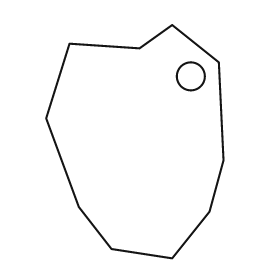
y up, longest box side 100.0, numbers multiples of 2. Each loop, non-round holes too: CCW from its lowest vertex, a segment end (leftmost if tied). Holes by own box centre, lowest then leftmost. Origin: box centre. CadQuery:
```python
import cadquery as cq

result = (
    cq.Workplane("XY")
    .moveTo(16.0, -50.0)
    .lineTo(32.0, -30.0)
    .lineTo(38.0, -8.0)
    .lineTo(36.0, 34.0)
    .lineTo(16.0, 50.0)
    .lineTo(2.0, 40.0)
    .lineTo(-28.0, 42.0)
    .lineTo(-38.0, 10.0)
    .lineTo(-24.0, -28.0)
    .lineTo(-10.0, -46.0)
    .close()
    .moveTo(24.0, 28.0)
    .circle(6.0)
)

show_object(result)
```